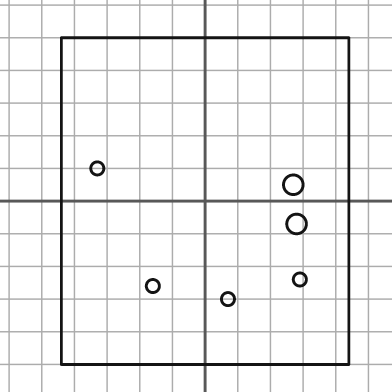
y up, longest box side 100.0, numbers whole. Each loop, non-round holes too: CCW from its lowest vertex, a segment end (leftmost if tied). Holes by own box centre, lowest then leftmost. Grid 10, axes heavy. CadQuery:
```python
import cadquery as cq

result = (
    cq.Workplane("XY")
    .moveTo(-44.0, -50.0)
    .lineTo(44.0, -50.0)
    .lineTo(44.0, 50.0)
    .lineTo(-44.0, 50.0)
    .close()
    .moveTo(7.0, -30.0)
    .circle(2.0)
    .moveTo(-16.0, -26.0)
    .circle(2.0)
    .moveTo(29.0, -24.0)
    .circle(2.0)
    .moveTo(28.0, -7.0)
    .circle(3.0)
    .moveTo(27.0, 5.0)
    .circle(3.0)
    .moveTo(-33.0, 10.0)
    .circle(2.0)
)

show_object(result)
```